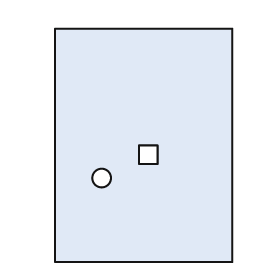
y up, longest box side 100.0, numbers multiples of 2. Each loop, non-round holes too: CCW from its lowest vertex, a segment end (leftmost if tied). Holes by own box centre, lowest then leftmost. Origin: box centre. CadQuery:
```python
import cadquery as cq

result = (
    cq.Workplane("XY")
    .moveTo(-38.0, -50.0)
    .lineTo(38.0, -50.0)
    .lineTo(38.0, 50.0)
    .lineTo(-38.0, 50.0)
    .close()
    .moveTo(-18.0, -14.0)
    .circle(4.0)
    .moveTo(-2.0, -8.0)
    .lineTo(6.0, -8.0)
    .lineTo(6.0, 0.0)
    .lineTo(-2.0, 0.0)
    .close()
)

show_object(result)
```